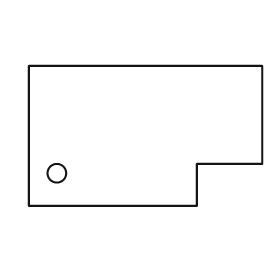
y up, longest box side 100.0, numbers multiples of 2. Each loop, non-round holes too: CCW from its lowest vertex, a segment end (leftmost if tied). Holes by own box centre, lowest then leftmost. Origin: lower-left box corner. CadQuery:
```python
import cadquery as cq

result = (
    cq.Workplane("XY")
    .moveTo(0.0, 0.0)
    .lineTo(72.0, 0.0)
    .lineTo(72.0, 18.0)
    .lineTo(100.0, 18.0)
    .lineTo(100.0, 60.0)
    .lineTo(0.0, 60.0)
    .close()
    .moveTo(12.0, 14.0)
    .circle(4.0)
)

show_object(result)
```